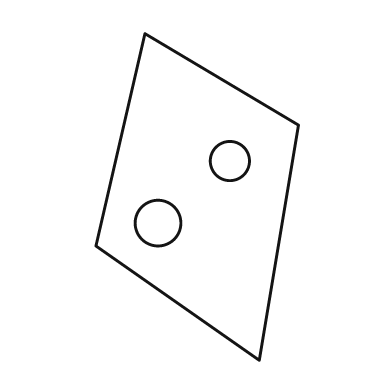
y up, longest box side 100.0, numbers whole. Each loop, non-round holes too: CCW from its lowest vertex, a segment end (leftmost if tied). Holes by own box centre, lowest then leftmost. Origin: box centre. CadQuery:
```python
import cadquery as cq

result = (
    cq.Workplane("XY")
    .moveTo(19.0, -50.0)
    .lineTo(31.0, 22.0)
    .lineTo(-16.0, 50.0)
    .lineTo(-31.0, -15.0)
    .close()
    .moveTo(-12.0, -8.0)
    .circle(7.0)
    .moveTo(10.0, 11.0)
    .circle(6.0)
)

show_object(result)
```